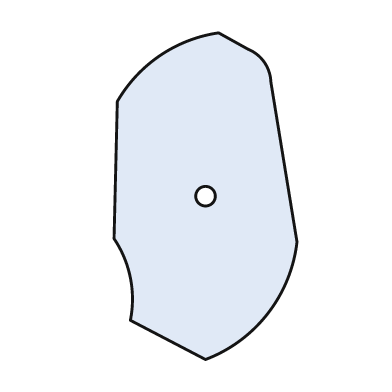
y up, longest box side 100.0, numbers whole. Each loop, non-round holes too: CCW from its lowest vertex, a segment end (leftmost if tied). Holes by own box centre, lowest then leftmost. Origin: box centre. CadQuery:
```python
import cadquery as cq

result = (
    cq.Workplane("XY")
    .moveTo(0.0, -50.0)
    .threePointArc((19.0, -36.0), (28.0, -14.0))
    .lineTo(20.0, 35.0)
    .threePointArc((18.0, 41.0), (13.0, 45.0))
    .lineTo(4.0, 50.0)
    .threePointArc((-14.0, 43.0), (-27.0, 29.0))
    .lineTo(-28.0, -13.0)
    .threePointArc((-23.0, -25.0), (-23.0, -38.0))
    .close()
    .moveTo(0.0, 0.0)
    .circle(3.0)
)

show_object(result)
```